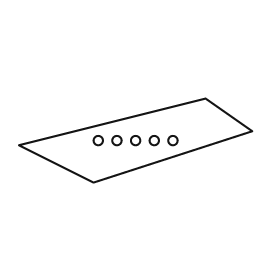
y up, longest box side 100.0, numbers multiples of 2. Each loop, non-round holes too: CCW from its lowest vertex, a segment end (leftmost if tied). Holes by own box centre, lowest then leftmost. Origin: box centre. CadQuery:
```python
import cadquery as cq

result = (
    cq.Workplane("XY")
    .moveTo(-18.0, -18.0)
    .lineTo(50.0, 4.0)
    .lineTo(30.0, 18.0)
    .lineTo(-50.0, -2.0)
    .close()
    .moveTo(-16.0, 0.0)
    .circle(2.0)
    .moveTo(-8.0, 0.0)
    .circle(2.0)
    .moveTo(0.0, 0.0)
    .circle(2.0)
    .moveTo(8.0, 0.0)
    .circle(2.0)
    .moveTo(16.0, 0.0)
    .circle(2.0)
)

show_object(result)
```